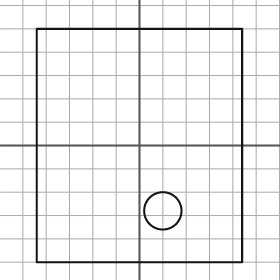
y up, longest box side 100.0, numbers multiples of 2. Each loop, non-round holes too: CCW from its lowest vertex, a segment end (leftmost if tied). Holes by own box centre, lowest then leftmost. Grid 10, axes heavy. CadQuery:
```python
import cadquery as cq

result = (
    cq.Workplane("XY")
    .moveTo(-44.0, -50.0)
    .lineTo(44.0, -50.0)
    .lineTo(44.0, 50.0)
    .lineTo(-44.0, 50.0)
    .close()
    .moveTo(10.0, -28.0)
    .circle(8.0)
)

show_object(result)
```